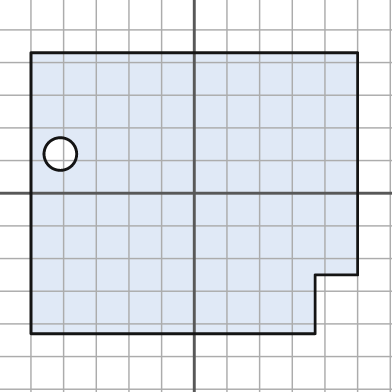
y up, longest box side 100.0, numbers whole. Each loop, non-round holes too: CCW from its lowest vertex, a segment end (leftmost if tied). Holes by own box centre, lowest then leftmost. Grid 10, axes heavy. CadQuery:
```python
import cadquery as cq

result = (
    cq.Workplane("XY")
    .moveTo(-50.0, -43.0)
    .lineTo(37.0, -43.0)
    .lineTo(37.0, -25.0)
    .lineTo(50.0, -25.0)
    .lineTo(50.0, 43.0)
    .lineTo(-50.0, 43.0)
    .close()
    .moveTo(-41.0, 12.0)
    .circle(5.0)
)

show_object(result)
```